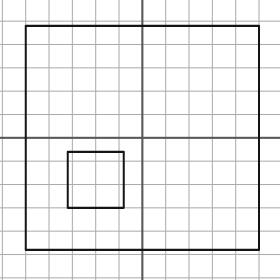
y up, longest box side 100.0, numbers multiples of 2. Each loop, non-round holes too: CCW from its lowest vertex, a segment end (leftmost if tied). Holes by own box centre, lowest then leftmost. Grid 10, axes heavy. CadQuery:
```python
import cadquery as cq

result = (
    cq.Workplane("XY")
    .moveTo(-50.0, -48.0)
    .lineTo(50.0, -48.0)
    .lineTo(50.0, 48.0)
    .lineTo(-50.0, 48.0)
    .close()
    .moveTo(-32.0, -30.0)
    .lineTo(-8.0, -30.0)
    .lineTo(-8.0, -6.0)
    .lineTo(-32.0, -6.0)
    .close()
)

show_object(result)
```